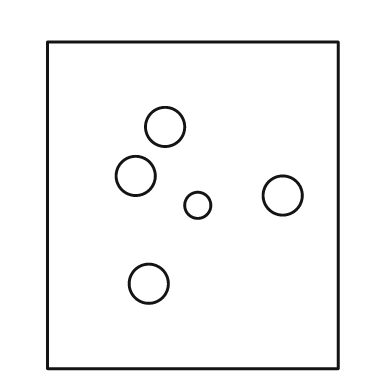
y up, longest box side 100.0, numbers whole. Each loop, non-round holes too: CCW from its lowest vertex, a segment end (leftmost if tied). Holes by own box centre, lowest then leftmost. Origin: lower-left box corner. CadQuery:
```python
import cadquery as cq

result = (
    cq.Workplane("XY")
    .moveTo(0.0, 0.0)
    .lineTo(89.0, 0.0)
    .lineTo(89.0, 100.0)
    .lineTo(0.0, 100.0)
    .close()
    .moveTo(31.0, 26.0)
    .circle(6.0)
    .moveTo(46.0, 50.0)
    .circle(4.0)
    .moveTo(72.0, 53.0)
    .circle(6.0)
    .moveTo(27.0, 59.0)
    .circle(6.0)
    .moveTo(36.0, 74.0)
    .circle(6.0)
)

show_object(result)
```